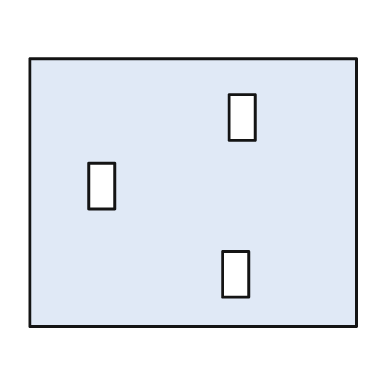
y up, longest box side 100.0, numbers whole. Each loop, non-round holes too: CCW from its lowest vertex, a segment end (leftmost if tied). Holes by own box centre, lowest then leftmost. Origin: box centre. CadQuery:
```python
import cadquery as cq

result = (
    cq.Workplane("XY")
    .moveTo(-50.0, -41.0)
    .lineTo(50.0, -41.0)
    .lineTo(50.0, 41.0)
    .lineTo(-50.0, 41.0)
    .close()
    .moveTo(9.0, -32.0)
    .lineTo(17.0, -32.0)
    .lineTo(17.0, -18.0)
    .lineTo(9.0, -18.0)
    .close()
    .moveTo(-32.0, -5.0)
    .lineTo(-24.0, -5.0)
    .lineTo(-24.0, 9.0)
    .lineTo(-32.0, 9.0)
    .close()
    .moveTo(11.0, 16.0)
    .lineTo(19.0, 16.0)
    .lineTo(19.0, 30.0)
    .lineTo(11.0, 30.0)
    .close()
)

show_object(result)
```